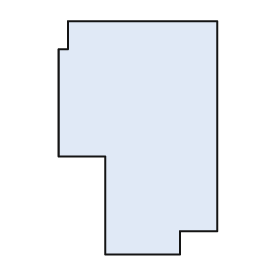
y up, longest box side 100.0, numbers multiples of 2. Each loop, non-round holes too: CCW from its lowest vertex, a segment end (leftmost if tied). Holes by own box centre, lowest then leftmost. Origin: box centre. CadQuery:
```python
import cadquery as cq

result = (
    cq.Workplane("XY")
    .moveTo(-14.0, -50.0)
    .lineTo(18.0, -50.0)
    .lineTo(18.0, -40.0)
    .lineTo(34.0, -40.0)
    .lineTo(34.0, 50.0)
    .lineTo(-30.0, 50.0)
    .lineTo(-30.0, 38.0)
    .lineTo(-34.0, 38.0)
    .lineTo(-34.0, -8.0)
    .lineTo(-14.0, -8.0)
    .close()
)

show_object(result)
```